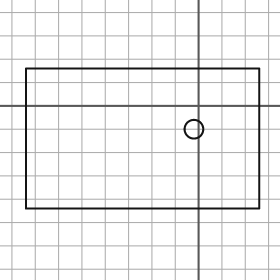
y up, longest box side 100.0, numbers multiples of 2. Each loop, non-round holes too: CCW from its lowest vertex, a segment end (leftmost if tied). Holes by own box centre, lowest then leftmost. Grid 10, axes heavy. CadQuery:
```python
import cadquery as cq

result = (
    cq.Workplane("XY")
    .moveTo(-74.0, -44.0)
    .lineTo(26.0, -44.0)
    .lineTo(26.0, 16.0)
    .lineTo(-74.0, 16.0)
    .close()
    .moveTo(-2.0, -10.0)
    .circle(4.0)
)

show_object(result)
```